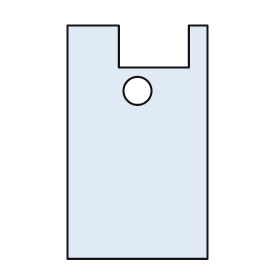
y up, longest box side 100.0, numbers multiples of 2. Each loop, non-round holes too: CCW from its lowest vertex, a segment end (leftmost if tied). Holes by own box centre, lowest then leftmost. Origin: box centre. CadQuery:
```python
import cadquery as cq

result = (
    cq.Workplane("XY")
    .moveTo(-30.0, -50.0)
    .lineTo(30.0, -50.0)
    .lineTo(30.0, 50.0)
    .lineTo(22.0, 50.0)
    .lineTo(22.0, 32.0)
    .lineTo(-8.0, 32.0)
    .lineTo(-8.0, 50.0)
    .lineTo(-30.0, 50.0)
    .close()
    .moveTo(0.0, 22.0)
    .circle(6.0)
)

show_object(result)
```